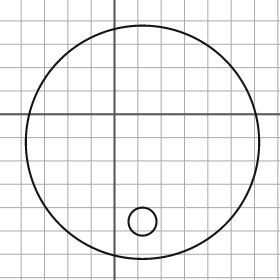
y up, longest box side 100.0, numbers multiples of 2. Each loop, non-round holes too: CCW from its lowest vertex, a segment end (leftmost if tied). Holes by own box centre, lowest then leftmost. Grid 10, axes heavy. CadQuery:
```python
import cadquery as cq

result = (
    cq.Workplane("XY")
    .moveTo(12.0, -12.0)
    .circle(50.0)
    .moveTo(12.0, -46.0)
    .circle(6.0)
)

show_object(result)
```